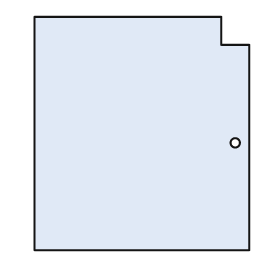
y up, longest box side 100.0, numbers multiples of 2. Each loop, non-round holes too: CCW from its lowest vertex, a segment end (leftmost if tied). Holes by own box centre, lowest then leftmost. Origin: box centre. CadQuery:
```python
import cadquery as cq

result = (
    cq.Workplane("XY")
    .moveTo(-46.0, -50.0)
    .lineTo(46.0, -50.0)
    .lineTo(46.0, 38.0)
    .lineTo(34.0, 38.0)
    .lineTo(34.0, 50.0)
    .lineTo(-46.0, 50.0)
    .close()
    .moveTo(40.0, -4.0)
    .circle(2.0)
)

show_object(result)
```